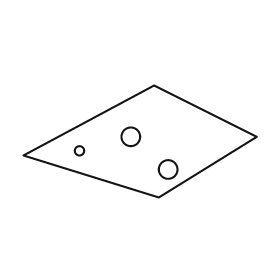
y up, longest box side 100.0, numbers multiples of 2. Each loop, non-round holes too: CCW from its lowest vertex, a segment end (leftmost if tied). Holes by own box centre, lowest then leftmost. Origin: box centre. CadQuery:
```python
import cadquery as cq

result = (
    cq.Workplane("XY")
    .moveTo(8.0, -24.0)
    .lineTo(50.0, 2.0)
    .lineTo(6.0, 24.0)
    .lineTo(-50.0, -6.0)
    .close()
    .moveTo(12.0, -12.0)
    .circle(4.0)
    .moveTo(-26.0, -4.0)
    .circle(2.0)
    .moveTo(-4.0, 2.0)
    .circle(4.0)
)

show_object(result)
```